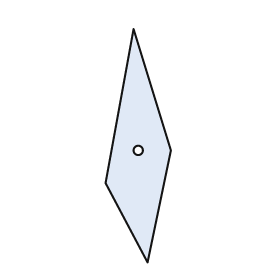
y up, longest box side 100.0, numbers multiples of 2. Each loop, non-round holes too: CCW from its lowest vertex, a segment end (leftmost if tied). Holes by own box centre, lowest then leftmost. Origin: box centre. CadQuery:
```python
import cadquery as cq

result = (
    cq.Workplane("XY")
    .moveTo(4.0, -50.0)
    .lineTo(14.0, -2.0)
    .lineTo(-2.0, 50.0)
    .lineTo(-14.0, -16.0)
    .close()
    .moveTo(0.0, -2.0)
    .circle(2.0)
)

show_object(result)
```